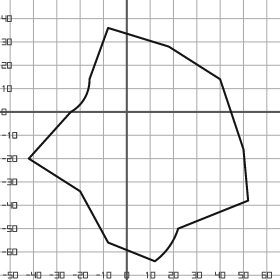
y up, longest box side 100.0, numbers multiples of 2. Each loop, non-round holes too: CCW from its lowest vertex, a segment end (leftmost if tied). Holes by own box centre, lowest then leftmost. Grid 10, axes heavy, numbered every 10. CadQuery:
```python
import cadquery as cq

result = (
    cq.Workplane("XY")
    .moveTo(12.0, -64.0)
    .threePointArc((18.0, -58.0), (22.0, -50.0))
    .lineTo(52.0, -38.0)
    .lineTo(50.0, -16.0)
    .lineTo(40.0, 14.0)
    .lineTo(18.0, 28.0)
    .lineTo(-8.0, 36.0)
    .lineTo(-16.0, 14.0)
    .threePointArc((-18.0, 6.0), (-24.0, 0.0))
    .lineTo(-42.0, -20.0)
    .lineTo(-20.0, -34.0)
    .lineTo(-8.0, -56.0)
    .close()
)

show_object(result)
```